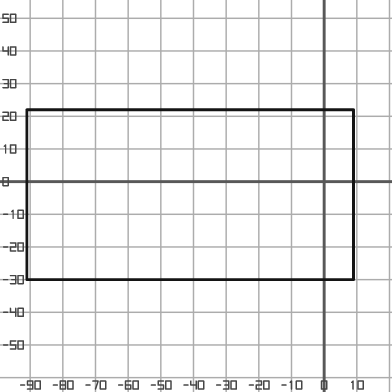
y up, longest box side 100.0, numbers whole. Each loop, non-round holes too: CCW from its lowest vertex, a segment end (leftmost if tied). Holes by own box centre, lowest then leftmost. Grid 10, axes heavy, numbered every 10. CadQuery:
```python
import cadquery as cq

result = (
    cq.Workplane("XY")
    .moveTo(-91.0, -30.0)
    .lineTo(9.0, -30.0)
    .lineTo(9.0, 22.0)
    .lineTo(-91.0, 22.0)
    .close()
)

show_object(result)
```